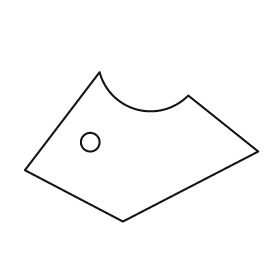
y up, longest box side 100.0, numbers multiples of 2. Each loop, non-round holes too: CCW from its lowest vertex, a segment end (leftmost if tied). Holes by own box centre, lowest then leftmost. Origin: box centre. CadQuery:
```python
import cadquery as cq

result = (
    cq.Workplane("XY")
    .moveTo(-8.0, -32.0)
    .lineTo(50.0, -2.0)
    .lineTo(20.0, 22.0)
    .threePointArc((-2.0, 16.0), (-18.0, 32.0))
    .lineTo(-50.0, -10.0)
    .close()
    .moveTo(-22.0, 2.0)
    .circle(4.0)
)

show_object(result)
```